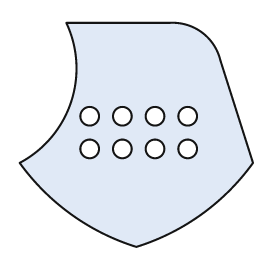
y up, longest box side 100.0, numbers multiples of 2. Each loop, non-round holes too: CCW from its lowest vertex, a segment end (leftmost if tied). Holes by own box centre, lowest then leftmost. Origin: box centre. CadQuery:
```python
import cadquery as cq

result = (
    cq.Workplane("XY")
    .moveTo(0.0, -48.0)
    .threePointArc((28.0, -34.0), (50.0, -12.0))
    .lineTo(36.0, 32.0)
    .threePointArc((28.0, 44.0), (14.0, 48.0))
    .lineTo(-30.0, 48.0)
    .threePointArc((-28.0, 14.0), (-50.0, -12.0))
    .threePointArc((-28.0, -34.0), (0.0, -48.0))
    .close()
    .moveTo(-20.0, -6.0)
    .circle(4.0)
    .moveTo(-6.0, -6.0)
    .circle(4.0)
    .moveTo(8.0, -6.0)
    .circle(4.0)
    .moveTo(22.0, -6.0)
    .circle(4.0)
    .moveTo(-20.0, 8.0)
    .circle(4.0)
    .moveTo(-6.0, 8.0)
    .circle(4.0)
    .moveTo(8.0, 8.0)
    .circle(4.0)
    .moveTo(22.0, 8.0)
    .circle(4.0)
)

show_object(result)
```